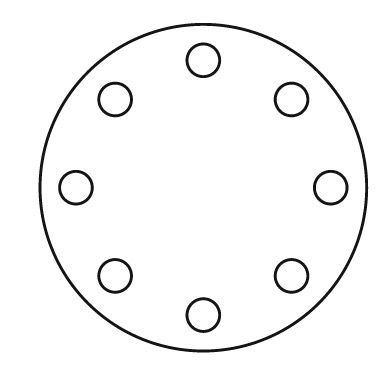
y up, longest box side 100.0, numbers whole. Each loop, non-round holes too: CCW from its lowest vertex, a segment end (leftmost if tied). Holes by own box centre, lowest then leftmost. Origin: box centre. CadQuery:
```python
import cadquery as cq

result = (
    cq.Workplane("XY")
    .moveTo(0.0, 0.0)
    .circle(50.0)
    .moveTo(0.0, -39.0)
    .circle(5.0)
    .moveTo(-27.0, -27.0)
    .circle(5.0)
    .moveTo(27.0, -27.0)
    .circle(5.0)
    .moveTo(-39.0, 0.0)
    .circle(5.0)
    .moveTo(39.0, 0.0)
    .circle(5.0)
    .moveTo(-27.0, 27.0)
    .circle(5.0)
    .moveTo(27.0, 27.0)
    .circle(5.0)
    .moveTo(0.0, 39.0)
    .circle(5.0)
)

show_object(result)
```